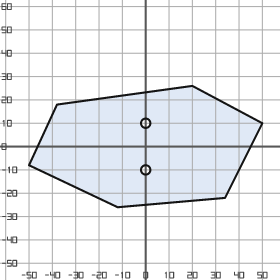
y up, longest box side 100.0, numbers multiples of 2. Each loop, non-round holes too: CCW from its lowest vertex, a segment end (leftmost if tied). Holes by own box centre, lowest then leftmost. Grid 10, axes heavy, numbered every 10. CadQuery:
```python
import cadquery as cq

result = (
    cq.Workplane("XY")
    .moveTo(-12.0, -26.0)
    .lineTo(34.0, -22.0)
    .lineTo(50.0, 10.0)
    .lineTo(20.0, 26.0)
    .lineTo(-38.0, 18.0)
    .lineTo(-50.0, -8.0)
    .close()
    .moveTo(0.0, -10.0)
    .circle(2.0)
    .moveTo(0.0, 10.0)
    .circle(2.0)
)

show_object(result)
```